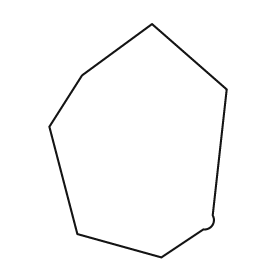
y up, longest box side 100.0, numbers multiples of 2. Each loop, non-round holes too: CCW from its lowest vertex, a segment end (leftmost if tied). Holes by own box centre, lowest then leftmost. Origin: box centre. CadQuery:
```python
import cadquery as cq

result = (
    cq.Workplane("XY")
    .moveTo(10.0, -50.0)
    .lineTo(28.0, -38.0)
    .threePointArc((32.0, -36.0), (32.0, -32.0))
    .lineTo(38.0, 22.0)
    .lineTo(6.0, 50.0)
    .lineTo(-24.0, 28.0)
    .lineTo(-38.0, 6.0)
    .lineTo(-26.0, -40.0)
    .close()
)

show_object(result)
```